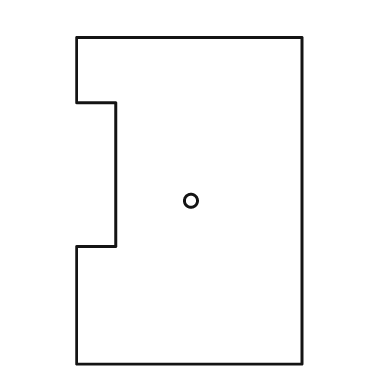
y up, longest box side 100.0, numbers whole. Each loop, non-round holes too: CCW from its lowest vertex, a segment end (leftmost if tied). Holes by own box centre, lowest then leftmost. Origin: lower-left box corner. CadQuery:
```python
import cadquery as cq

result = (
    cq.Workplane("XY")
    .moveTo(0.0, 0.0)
    .lineTo(69.0, 0.0)
    .lineTo(69.0, 100.0)
    .lineTo(0.0, 100.0)
    .lineTo(0.0, 80.0)
    .lineTo(12.0, 80.0)
    .lineTo(12.0, 36.0)
    .lineTo(0.0, 36.0)
    .close()
    .moveTo(35.0, 50.0)
    .circle(2.0)
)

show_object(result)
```